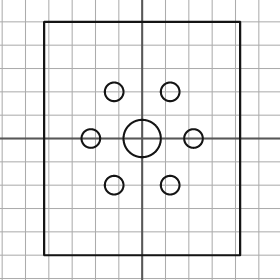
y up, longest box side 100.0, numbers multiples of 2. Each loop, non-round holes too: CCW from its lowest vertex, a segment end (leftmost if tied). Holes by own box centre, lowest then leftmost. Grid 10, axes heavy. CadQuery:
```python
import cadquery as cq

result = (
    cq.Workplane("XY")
    .moveTo(-42.0, -50.0)
    .lineTo(42.0, -50.0)
    .lineTo(42.0, 50.0)
    .lineTo(-42.0, 50.0)
    .close()
    .moveTo(-12.0, -20.0)
    .circle(4.0)
    .moveTo(12.0, -20.0)
    .circle(4.0)
    .moveTo(-22.0, 0.0)
    .circle(4.0)
    .moveTo(0.0, 0.0)
    .circle(8.0)
    .moveTo(22.0, 0.0)
    .circle(4.0)
    .moveTo(-12.0, 20.0)
    .circle(4.0)
    .moveTo(12.0, 20.0)
    .circle(4.0)
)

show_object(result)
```